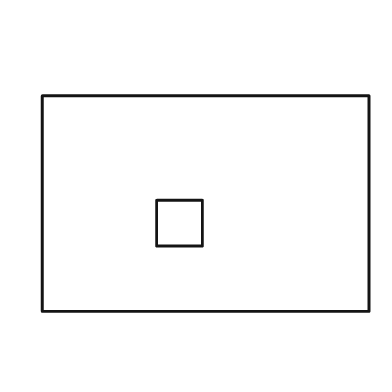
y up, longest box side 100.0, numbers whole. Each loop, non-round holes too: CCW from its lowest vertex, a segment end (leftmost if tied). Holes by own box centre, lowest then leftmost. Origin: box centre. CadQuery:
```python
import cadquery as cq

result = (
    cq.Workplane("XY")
    .moveTo(-50.0, -33.0)
    .lineTo(50.0, -33.0)
    .lineTo(50.0, 33.0)
    .lineTo(-50.0, 33.0)
    .close()
    .moveTo(-15.0, -13.0)
    .lineTo(-1.0, -13.0)
    .lineTo(-1.0, 1.0)
    .lineTo(-15.0, 1.0)
    .close()
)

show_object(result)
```